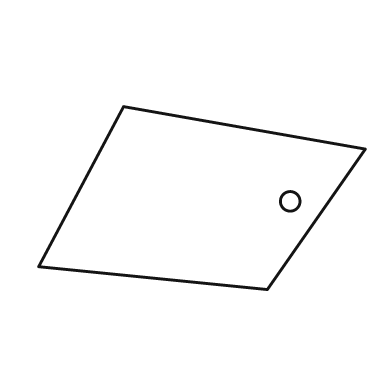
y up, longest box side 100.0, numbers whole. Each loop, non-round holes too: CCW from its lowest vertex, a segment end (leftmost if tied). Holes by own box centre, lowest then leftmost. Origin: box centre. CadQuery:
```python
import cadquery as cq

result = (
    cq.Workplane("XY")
    .moveTo(20.0, -28.0)
    .lineTo(50.0, 15.0)
    .lineTo(-24.0, 28.0)
    .lineTo(-50.0, -21.0)
    .close()
    .moveTo(27.0, -1.0)
    .circle(3.0)
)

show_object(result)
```